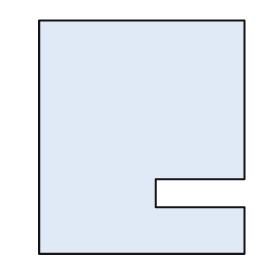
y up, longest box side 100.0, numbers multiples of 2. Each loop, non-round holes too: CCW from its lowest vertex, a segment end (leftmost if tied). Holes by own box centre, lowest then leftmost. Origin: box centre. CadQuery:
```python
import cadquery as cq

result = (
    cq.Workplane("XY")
    .moveTo(-44.0, -50.0)
    .lineTo(44.0, -50.0)
    .lineTo(44.0, -30.0)
    .lineTo(6.0, -30.0)
    .lineTo(6.0, -18.0)
    .lineTo(44.0, -18.0)
    .lineTo(44.0, 50.0)
    .lineTo(-44.0, 50.0)
    .close()
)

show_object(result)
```